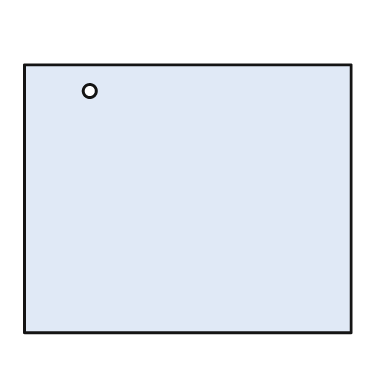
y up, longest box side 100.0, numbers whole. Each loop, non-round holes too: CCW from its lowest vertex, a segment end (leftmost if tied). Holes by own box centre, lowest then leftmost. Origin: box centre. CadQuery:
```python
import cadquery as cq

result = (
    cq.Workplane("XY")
    .moveTo(-50.0, -41.0)
    .lineTo(50.0, -41.0)
    .lineTo(50.0, 41.0)
    .lineTo(-50.0, 41.0)
    .close()
    .moveTo(-30.0, 33.0)
    .circle(2.0)
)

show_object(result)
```